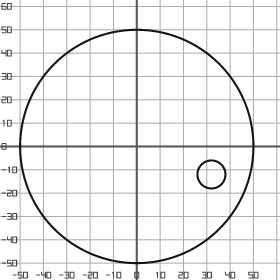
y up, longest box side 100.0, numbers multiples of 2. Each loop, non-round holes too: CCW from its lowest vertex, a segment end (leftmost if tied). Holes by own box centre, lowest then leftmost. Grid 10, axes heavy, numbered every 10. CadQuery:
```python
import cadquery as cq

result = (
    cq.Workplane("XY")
    .moveTo(0.0, 0.0)
    .circle(50.0)
    .moveTo(32.0, -12.0)
    .circle(6.0)
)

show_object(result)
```